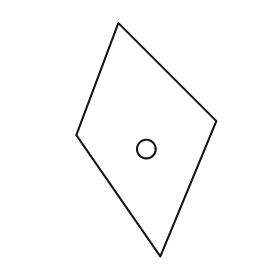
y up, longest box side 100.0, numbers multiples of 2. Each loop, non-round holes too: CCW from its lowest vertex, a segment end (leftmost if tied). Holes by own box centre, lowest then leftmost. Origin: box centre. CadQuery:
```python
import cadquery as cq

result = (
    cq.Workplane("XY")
    .moveTo(6.0, -50.0)
    .lineTo(30.0, 8.0)
    .lineTo(-12.0, 50.0)
    .lineTo(-30.0, 2.0)
    .close()
    .moveTo(0.0, -4.0)
    .circle(4.0)
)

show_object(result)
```